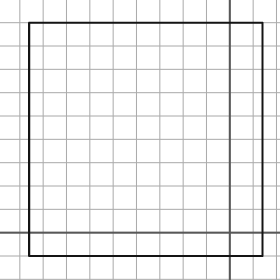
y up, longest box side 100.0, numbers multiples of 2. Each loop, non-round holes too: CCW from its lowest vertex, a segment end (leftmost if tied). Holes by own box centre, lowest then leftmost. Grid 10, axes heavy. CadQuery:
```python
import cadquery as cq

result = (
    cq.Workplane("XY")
    .moveTo(-86.0, -10.0)
    .lineTo(14.0, -10.0)
    .lineTo(14.0, 90.0)
    .lineTo(-86.0, 90.0)
    .close()
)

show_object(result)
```